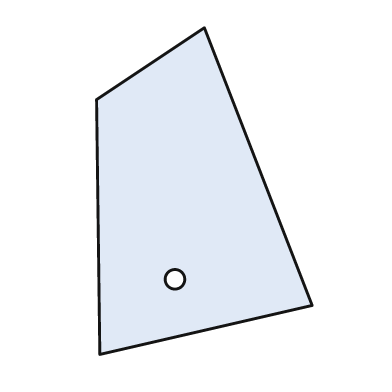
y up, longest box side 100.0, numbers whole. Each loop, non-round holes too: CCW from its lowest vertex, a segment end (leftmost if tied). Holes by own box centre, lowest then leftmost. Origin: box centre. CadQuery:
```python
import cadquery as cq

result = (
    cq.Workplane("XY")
    .moveTo(-32.0, -50.0)
    .lineTo(33.0, -35.0)
    .lineTo(0.0, 50.0)
    .lineTo(-33.0, 28.0)
    .close()
    .moveTo(-9.0, -27.0)
    .circle(3.0)
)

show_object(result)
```